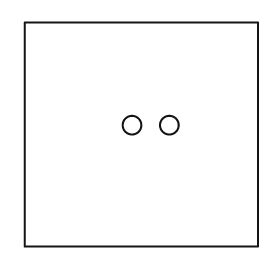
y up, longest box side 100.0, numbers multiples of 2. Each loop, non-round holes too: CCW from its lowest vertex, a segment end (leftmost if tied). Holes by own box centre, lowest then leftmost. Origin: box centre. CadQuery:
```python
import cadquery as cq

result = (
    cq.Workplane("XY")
    .moveTo(-50.0, -48.0)
    .lineTo(50.0, -48.0)
    .lineTo(50.0, 48.0)
    .lineTo(-50.0, 48.0)
    .close()
    .moveTo(-4.0, 4.0)
    .circle(4.0)
    .moveTo(12.0, 4.0)
    .circle(4.0)
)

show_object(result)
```